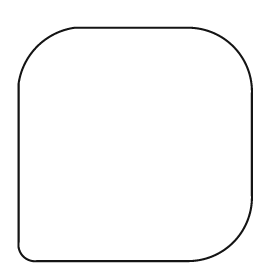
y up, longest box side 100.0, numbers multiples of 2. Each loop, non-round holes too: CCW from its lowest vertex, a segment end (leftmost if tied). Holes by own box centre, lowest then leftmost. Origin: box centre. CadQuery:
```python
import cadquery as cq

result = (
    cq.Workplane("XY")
    .moveTo(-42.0, -50.0)
    .lineTo(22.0, -50.0)
    .threePointArc((42.0, -42.0), (50.0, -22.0))
    .lineTo(50.0, 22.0)
    .threePointArc((42.0, 42.0), (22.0, 50.0))
    .lineTo(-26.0, 50.0)
    .threePointArc((-42.0, 42.0), (-50.0, 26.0))
    .lineTo(-50.0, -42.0)
    .threePointArc((-48.0, -48.0), (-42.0, -50.0))
    .close()
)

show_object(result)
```